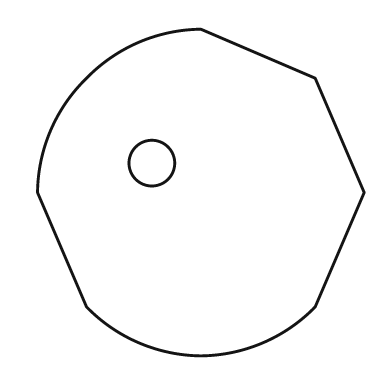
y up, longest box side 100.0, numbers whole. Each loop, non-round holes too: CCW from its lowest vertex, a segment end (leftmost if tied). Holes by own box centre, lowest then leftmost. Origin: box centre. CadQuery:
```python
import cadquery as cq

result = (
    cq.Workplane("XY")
    .moveTo(0.0, -50.0)
    .threePointArc((19.0, -46.0), (35.0, -35.0))
    .lineTo(50.0, 0.0)
    .lineTo(35.0, 35.0)
    .lineTo(0.0, 50.0)
    .threePointArc((-19.0, 46.0), (-35.0, 35.0))
    .threePointArc((-46.0, 19.0), (-50.0, 0.0))
    .lineTo(-35.0, -35.0)
    .threePointArc((-19.0, -46.0), (0.0, -50.0))
    .close()
    .moveTo(-15.0, 9.0)
    .circle(7.0)
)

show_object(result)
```